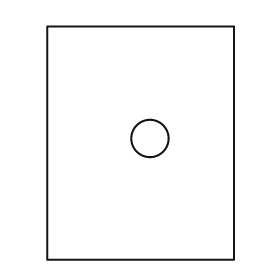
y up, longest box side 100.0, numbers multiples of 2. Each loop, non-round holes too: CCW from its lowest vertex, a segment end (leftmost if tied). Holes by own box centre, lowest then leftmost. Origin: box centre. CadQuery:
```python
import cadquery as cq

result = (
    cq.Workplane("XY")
    .moveTo(-40.0, -50.0)
    .lineTo(40.0, -50.0)
    .lineTo(40.0, 50.0)
    .lineTo(-40.0, 50.0)
    .close()
    .moveTo(4.0, 2.0)
    .circle(8.0)
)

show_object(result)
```